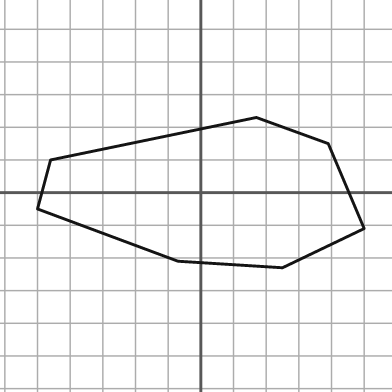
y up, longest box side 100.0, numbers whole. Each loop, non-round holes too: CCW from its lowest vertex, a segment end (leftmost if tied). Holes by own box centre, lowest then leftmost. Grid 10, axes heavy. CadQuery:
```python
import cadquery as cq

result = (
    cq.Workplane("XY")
    .moveTo(25.0, -23.0)
    .lineTo(50.0, -11.0)
    .lineTo(39.0, 15.0)
    .lineTo(17.0, 23.0)
    .lineTo(-46.0, 10.0)
    .lineTo(-50.0, -5.0)
    .lineTo(-7.0, -21.0)
    .close()
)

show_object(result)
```